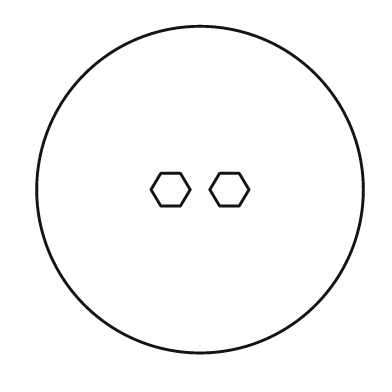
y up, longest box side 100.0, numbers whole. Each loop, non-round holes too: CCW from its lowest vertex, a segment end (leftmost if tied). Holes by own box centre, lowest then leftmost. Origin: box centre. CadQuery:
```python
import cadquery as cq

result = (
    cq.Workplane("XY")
    .moveTo(0.0, 0.0)
    .circle(50.0)
    .moveTo(-12.0, -5.0)
    .lineTo(-6.0, -5.0)
    .lineTo(-3.0, 0.0)
    .lineTo(-6.0, 5.0)
    .lineTo(-12.0, 5.0)
    .lineTo(-15.0, 0.0)
    .close()
    .moveTo(6.0, -5.0)
    .lineTo(12.0, -5.0)
    .lineTo(15.0, 0.0)
    .lineTo(12.0, 5.0)
    .lineTo(6.0, 5.0)
    .lineTo(3.0, 0.0)
    .close()
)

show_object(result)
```